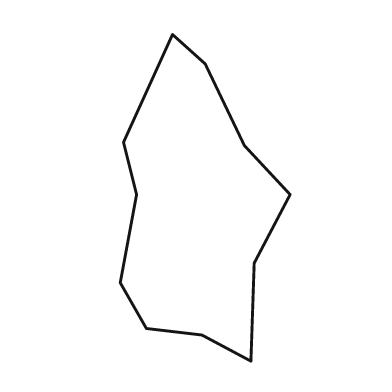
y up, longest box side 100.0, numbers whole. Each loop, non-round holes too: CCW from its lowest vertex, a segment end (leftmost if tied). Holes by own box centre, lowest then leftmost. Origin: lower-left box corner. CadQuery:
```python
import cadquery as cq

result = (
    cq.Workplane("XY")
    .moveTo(40.0, 0.0)
    .lineTo(41.0, 30.0)
    .lineTo(52.0, 51.0)
    .lineTo(38.0, 66.0)
    .lineTo(26.0, 91.0)
    .lineTo(16.0, 100.0)
    .lineTo(1.0, 67.0)
    .lineTo(5.0, 51.0)
    .lineTo(0.0, 24.0)
    .lineTo(8.0, 10.0)
    .lineTo(25.0, 8.0)
    .close()
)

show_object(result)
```